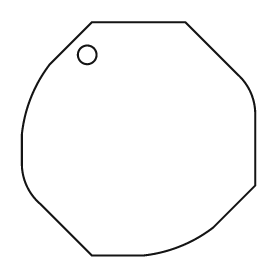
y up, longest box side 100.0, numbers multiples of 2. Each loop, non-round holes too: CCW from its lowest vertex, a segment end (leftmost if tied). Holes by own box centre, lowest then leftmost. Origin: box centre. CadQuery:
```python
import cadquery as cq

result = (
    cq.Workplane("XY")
    .moveTo(-20.0, -50.0)
    .lineTo(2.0, -50.0)
    .threePointArc((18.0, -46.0), (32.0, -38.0))
    .lineTo(50.0, -20.0)
    .lineTo(50.0, 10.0)
    .threePointArc((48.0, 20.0), (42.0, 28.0))
    .lineTo(20.0, 50.0)
    .lineTo(-20.0, 50.0)
    .lineTo(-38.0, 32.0)
    .threePointArc((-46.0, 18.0), (-50.0, 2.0))
    .lineTo(-50.0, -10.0)
    .threePointArc((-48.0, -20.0), (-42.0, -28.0))
    .close()
    .moveTo(-22.0, 36.0)
    .circle(4.0)
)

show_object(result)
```